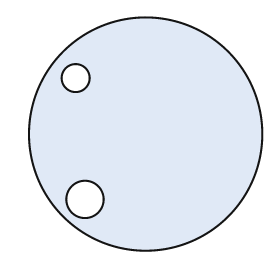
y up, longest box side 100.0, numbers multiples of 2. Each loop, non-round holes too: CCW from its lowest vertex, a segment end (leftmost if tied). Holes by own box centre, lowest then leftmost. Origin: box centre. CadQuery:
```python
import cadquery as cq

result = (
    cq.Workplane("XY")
    .moveTo(0.0, 0.0)
    .circle(50.0)
    .moveTo(-26.0, -28.0)
    .circle(8.0)
    .moveTo(-30.0, 24.0)
    .circle(6.0)
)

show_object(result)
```